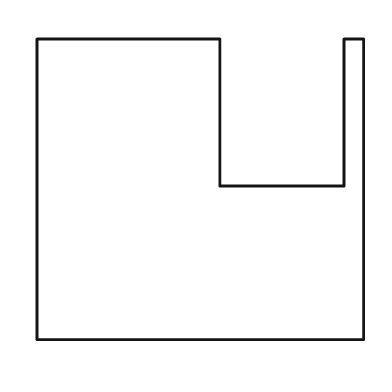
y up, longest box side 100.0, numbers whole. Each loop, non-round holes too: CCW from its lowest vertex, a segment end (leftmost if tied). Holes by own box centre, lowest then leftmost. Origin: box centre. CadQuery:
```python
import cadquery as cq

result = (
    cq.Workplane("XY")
    .moveTo(-50.0, -46.0)
    .lineTo(50.0, -46.0)
    .lineTo(50.0, 46.0)
    .lineTo(44.0, 46.0)
    .lineTo(44.0, 1.0)
    .lineTo(6.0, 1.0)
    .lineTo(6.0, 46.0)
    .lineTo(-50.0, 46.0)
    .close()
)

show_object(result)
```